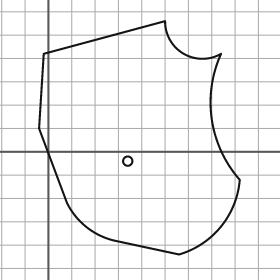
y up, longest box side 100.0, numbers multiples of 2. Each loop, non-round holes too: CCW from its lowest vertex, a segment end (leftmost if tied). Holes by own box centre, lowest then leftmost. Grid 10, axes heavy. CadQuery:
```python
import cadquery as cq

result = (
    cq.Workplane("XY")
    .moveTo(56.0, -44.0)
    .threePointArc((74.0, -32.0), (82.0, -12.0))
    .threePointArc((70.0, 14.0), (74.0, 42.0))
    .threePointArc((58.0, 42.0), (50.0, 56.0))
    .lineTo(-2.0, 42.0)
    .lineTo(-4.0, 10.0)
    .lineTo(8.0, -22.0)
    .threePointArc((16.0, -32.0), (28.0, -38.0))
    .close()
    .moveTo(34.0, -4.0)
    .circle(2.0)
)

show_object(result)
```